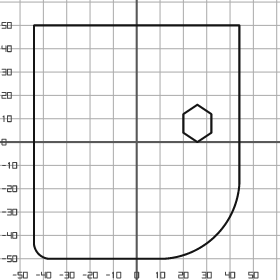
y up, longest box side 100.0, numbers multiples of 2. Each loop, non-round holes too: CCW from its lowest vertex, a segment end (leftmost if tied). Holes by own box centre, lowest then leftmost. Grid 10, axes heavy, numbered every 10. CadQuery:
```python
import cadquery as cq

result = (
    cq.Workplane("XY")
    .moveTo(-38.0, -50.0)
    .lineTo(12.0, -50.0)
    .threePointArc((34.0, -40.0), (44.0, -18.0))
    .lineTo(44.0, 50.0)
    .lineTo(-44.0, 50.0)
    .lineTo(-44.0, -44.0)
    .threePointArc((-42.0, -48.0), (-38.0, -50.0))
    .close()
    .moveTo(26.0, 0.0)
    .lineTo(32.0, 4.0)
    .lineTo(32.0, 12.0)
    .lineTo(26.0, 16.0)
    .lineTo(20.0, 12.0)
    .lineTo(20.0, 4.0)
    .close()
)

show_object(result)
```